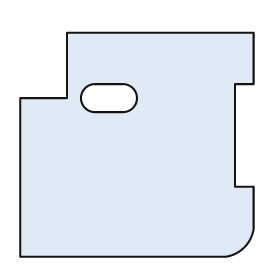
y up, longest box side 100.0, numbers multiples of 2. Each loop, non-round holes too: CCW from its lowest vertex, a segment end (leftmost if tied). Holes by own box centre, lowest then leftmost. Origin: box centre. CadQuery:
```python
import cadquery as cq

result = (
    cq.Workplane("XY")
    .moveTo(-50.0, -48.0)
    .lineTo(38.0, -48.0)
    .threePointArc((46.0, -44.0), (50.0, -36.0))
    .lineTo(50.0, -18.0)
    .lineTo(42.0, -18.0)
    .lineTo(42.0, 26.0)
    .lineTo(50.0, 26.0)
    .lineTo(50.0, 48.0)
    .lineTo(-30.0, 48.0)
    .lineTo(-30.0, 20.0)
    .lineTo(-50.0, 20.0)
    .close()
    .moveTo(-18.0, 14.0)
    .lineTo(-6.0, 14.0)
    .threePointArc((0.0, 20.0), (-6.0, 26.0))
    .lineTo(-18.0, 26.0)
    .threePointArc((-24.0, 20.0), (-18.0, 14.0))
    .close()
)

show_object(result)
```